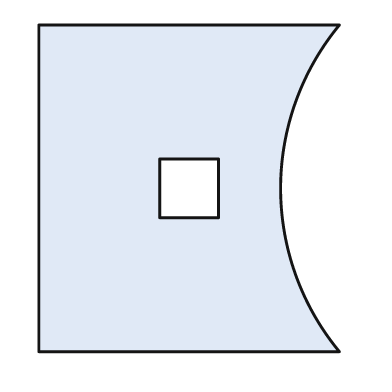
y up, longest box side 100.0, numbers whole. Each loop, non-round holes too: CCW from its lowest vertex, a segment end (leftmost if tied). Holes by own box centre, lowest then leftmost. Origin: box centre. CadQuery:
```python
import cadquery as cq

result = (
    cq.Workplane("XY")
    .moveTo(-46.0, -50.0)
    .lineTo(46.0, -50.0)
    .threePointArc((28.0, 0.0), (46.0, 50.0))
    .lineTo(-46.0, 50.0)
    .close()
    .moveTo(-9.0, -9.0)
    .lineTo(9.0, -9.0)
    .lineTo(9.0, 9.0)
    .lineTo(-9.0, 9.0)
    .close()
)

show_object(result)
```